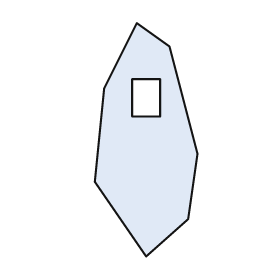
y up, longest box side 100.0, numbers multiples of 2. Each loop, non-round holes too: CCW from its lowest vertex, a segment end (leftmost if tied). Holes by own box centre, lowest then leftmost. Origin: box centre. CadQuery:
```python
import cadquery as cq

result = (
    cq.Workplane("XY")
    .moveTo(0.0, -50.0)
    .lineTo(18.0, -34.0)
    .lineTo(22.0, -6.0)
    .lineTo(10.0, 40.0)
    .lineTo(-4.0, 50.0)
    .lineTo(-18.0, 22.0)
    .lineTo(-22.0, -18.0)
    .close()
    .moveTo(-6.0, 10.0)
    .lineTo(6.0, 10.0)
    .lineTo(6.0, 26.0)
    .lineTo(-6.0, 26.0)
    .close()
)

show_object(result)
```